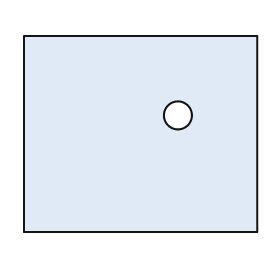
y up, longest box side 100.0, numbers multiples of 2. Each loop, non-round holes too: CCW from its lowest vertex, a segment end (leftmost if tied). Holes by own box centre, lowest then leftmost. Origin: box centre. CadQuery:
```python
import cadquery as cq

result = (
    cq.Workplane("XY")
    .moveTo(-50.0, -42.0)
    .lineTo(50.0, -42.0)
    .lineTo(50.0, 42.0)
    .lineTo(-50.0, 42.0)
    .close()
    .moveTo(16.0, 8.0)
    .circle(6.0)
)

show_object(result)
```